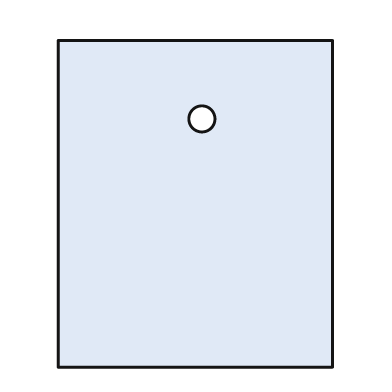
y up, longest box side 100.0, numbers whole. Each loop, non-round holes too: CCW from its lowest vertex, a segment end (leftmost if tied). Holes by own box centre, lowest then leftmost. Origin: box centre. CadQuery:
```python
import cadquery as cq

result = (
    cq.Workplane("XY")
    .moveTo(-42.0, -50.0)
    .lineTo(42.0, -50.0)
    .lineTo(42.0, 50.0)
    .lineTo(-42.0, 50.0)
    .close()
    .moveTo(2.0, 26.0)
    .circle(4.0)
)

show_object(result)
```